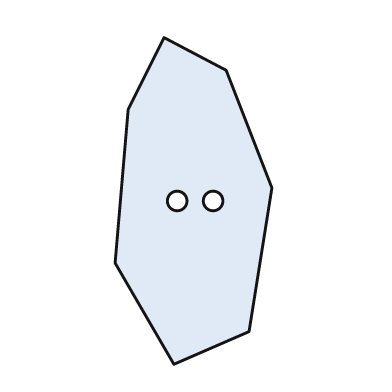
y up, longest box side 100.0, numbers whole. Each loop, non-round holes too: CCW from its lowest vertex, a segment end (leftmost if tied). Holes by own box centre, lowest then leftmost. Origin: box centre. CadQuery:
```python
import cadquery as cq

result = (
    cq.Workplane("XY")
    .moveTo(-6.0, -50.0)
    .lineTo(17.0, -40.0)
    .lineTo(24.0, 4.0)
    .lineTo(10.0, 40.0)
    .lineTo(-9.0, 50.0)
    .lineTo(-20.0, 28.0)
    .lineTo(-24.0, -19.0)
    .close()
    .moveTo(-5.0, 0.0)
    .circle(3.0)
    .moveTo(6.0, 0.0)
    .circle(3.0)
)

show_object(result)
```